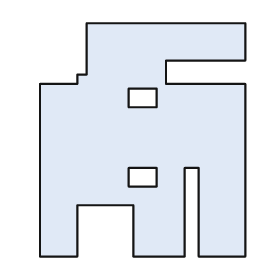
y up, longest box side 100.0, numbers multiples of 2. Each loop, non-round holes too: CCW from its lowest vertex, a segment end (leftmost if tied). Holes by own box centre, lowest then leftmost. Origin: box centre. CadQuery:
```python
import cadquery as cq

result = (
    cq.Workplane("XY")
    .moveTo(-44.0, -50.0)
    .lineTo(-28.0, -50.0)
    .lineTo(-28.0, -28.0)
    .lineTo(-4.0, -28.0)
    .lineTo(-4.0, -50.0)
    .lineTo(18.0, -50.0)
    .lineTo(18.0, -12.0)
    .lineTo(24.0, -12.0)
    .lineTo(24.0, -50.0)
    .lineTo(44.0, -50.0)
    .lineTo(44.0, 24.0)
    .lineTo(10.0, 24.0)
    .lineTo(10.0, 34.0)
    .lineTo(44.0, 34.0)
    .lineTo(44.0, 50.0)
    .lineTo(-24.0, 50.0)
    .lineTo(-24.0, 28.0)
    .lineTo(-28.0, 28.0)
    .lineTo(-28.0, 24.0)
    .lineTo(-44.0, 24.0)
    .close()
    .moveTo(-6.0, -20.0)
    .lineTo(6.0, -20.0)
    .lineTo(6.0, -12.0)
    .lineTo(-6.0, -12.0)
    .close()
    .moveTo(-6.0, 14.0)
    .lineTo(6.0, 14.0)
    .lineTo(6.0, 22.0)
    .lineTo(-6.0, 22.0)
    .close()
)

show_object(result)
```